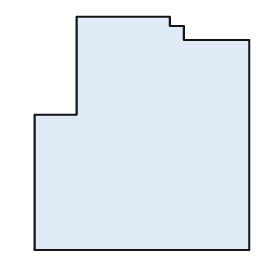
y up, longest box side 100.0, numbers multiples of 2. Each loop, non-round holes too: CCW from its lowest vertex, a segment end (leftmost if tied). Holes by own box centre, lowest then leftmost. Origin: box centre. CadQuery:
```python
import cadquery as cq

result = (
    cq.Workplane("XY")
    .moveTo(-46.0, -50.0)
    .lineTo(46.0, -50.0)
    .lineTo(46.0, 40.0)
    .lineTo(18.0, 40.0)
    .lineTo(18.0, 46.0)
    .lineTo(12.0, 46.0)
    .lineTo(12.0, 50.0)
    .lineTo(-28.0, 50.0)
    .lineTo(-28.0, 8.0)
    .lineTo(-46.0, 8.0)
    .close()
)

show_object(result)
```